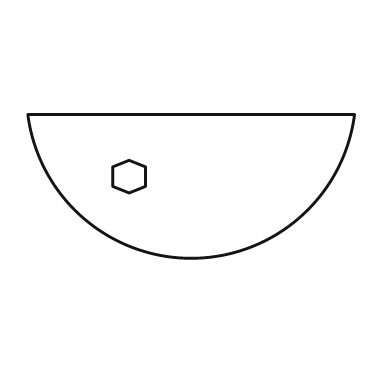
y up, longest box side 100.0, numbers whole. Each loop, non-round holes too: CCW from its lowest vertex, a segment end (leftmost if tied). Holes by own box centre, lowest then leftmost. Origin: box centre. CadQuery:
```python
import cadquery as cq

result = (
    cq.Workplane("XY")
    .moveTo(-50.0, 22.0)
    .threePointArc((0.0, -22.0), (50.0, 22.0))
    .close()
    .moveTo(-19.0, -2.0)
    .lineTo(-14.0, 0.0)
    .lineTo(-14.0, 6.0)
    .lineTo(-19.0, 8.0)
    .lineTo(-24.0, 6.0)
    .lineTo(-24.0, 0.0)
    .close()
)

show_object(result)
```